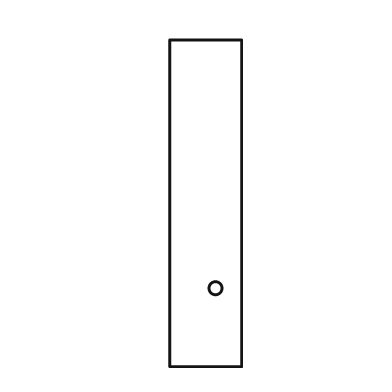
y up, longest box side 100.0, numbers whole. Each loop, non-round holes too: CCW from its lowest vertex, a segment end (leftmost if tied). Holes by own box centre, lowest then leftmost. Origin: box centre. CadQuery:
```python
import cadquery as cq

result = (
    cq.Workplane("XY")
    .moveTo(-11.0, -50.0)
    .lineTo(11.0, -50.0)
    .lineTo(11.0, 50.0)
    .lineTo(-11.0, 50.0)
    .close()
    .moveTo(3.0, -26.0)
    .circle(2.0)
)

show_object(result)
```